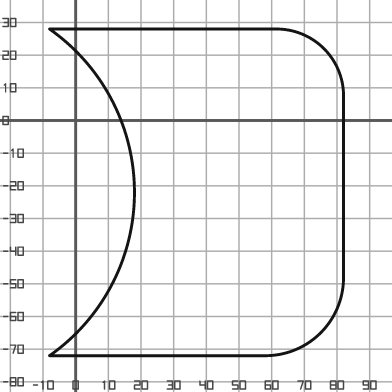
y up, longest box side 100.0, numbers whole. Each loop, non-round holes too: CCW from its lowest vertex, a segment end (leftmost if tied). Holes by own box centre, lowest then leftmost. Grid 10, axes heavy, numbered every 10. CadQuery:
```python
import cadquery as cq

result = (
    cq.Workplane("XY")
    .moveTo(-8.0, -72.0)
    .lineTo(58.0, -72.0)
    .threePointArc((75.0, -65.0), (82.0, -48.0))
    .lineTo(82.0, 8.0)
    .threePointArc((76.0, 22.0), (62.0, 28.0))
    .lineTo(-8.0, 28.0)
    .threePointArc((18.0, -22.0), (-8.0, -72.0))
    .close()
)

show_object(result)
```